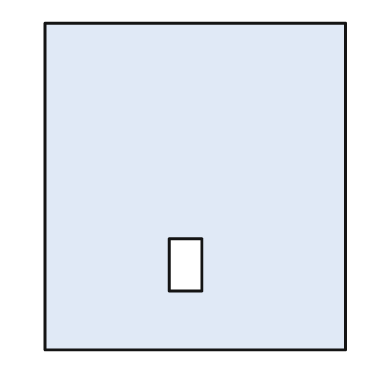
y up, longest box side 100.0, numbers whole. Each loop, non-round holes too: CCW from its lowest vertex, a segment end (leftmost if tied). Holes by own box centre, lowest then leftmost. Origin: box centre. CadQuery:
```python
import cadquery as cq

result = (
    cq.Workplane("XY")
    .moveTo(-46.0, -50.0)
    .lineTo(46.0, -50.0)
    .lineTo(46.0, 50.0)
    .lineTo(-46.0, 50.0)
    .close()
    .moveTo(-8.0, -32.0)
    .lineTo(2.0, -32.0)
    .lineTo(2.0, -16.0)
    .lineTo(-8.0, -16.0)
    .close()
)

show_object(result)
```